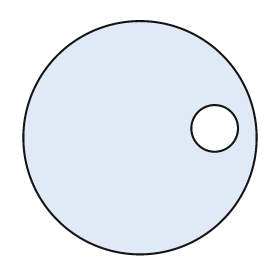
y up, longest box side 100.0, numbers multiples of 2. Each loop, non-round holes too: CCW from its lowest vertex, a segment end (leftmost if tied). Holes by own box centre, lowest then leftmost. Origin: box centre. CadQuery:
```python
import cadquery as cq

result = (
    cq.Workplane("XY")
    .moveTo(0.0, 0.0)
    .circle(50.0)
    .moveTo(32.0, 4.0)
    .circle(10.0)
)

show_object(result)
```